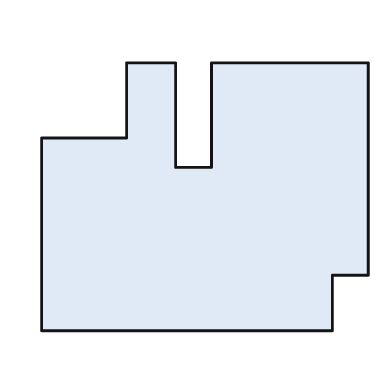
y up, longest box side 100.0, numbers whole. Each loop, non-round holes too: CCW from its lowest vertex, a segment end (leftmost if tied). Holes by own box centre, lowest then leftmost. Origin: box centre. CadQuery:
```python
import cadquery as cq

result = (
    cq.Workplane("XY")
    .moveTo(-50.0, -41.0)
    .lineTo(39.0, -41.0)
    .lineTo(39.0, -24.0)
    .lineTo(50.0, -24.0)
    .lineTo(50.0, 41.0)
    .lineTo(2.0, 41.0)
    .lineTo(2.0, 9.0)
    .lineTo(-9.0, 9.0)
    .lineTo(-9.0, 41.0)
    .lineTo(-24.0, 41.0)
    .lineTo(-24.0, 18.0)
    .lineTo(-50.0, 18.0)
    .close()
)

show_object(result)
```